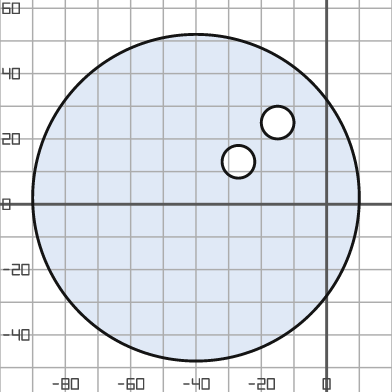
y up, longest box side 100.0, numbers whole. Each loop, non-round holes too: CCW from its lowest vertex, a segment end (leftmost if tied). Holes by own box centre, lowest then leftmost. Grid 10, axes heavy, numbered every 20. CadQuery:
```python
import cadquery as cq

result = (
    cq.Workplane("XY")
    .moveTo(-40.0, 2.0)
    .circle(50.0)
    .moveTo(-27.0, 13.0)
    .circle(5.0)
    .moveTo(-15.0, 25.0)
    .circle(5.0)
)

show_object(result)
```